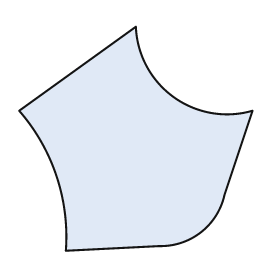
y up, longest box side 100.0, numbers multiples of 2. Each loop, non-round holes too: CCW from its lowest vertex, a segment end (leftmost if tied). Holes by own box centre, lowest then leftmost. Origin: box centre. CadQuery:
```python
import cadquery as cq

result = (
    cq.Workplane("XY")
    .moveTo(-30.0, -48.0)
    .lineTo(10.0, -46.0)
    .threePointArc((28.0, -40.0), (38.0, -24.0))
    .lineTo(50.0, 12.0)
    .threePointArc((16.0, 18.0), (0.0, 48.0))
    .lineTo(-50.0, 12.0)
    .threePointArc((-34.0, -16.0), (-30.0, -48.0))
    .close()
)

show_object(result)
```